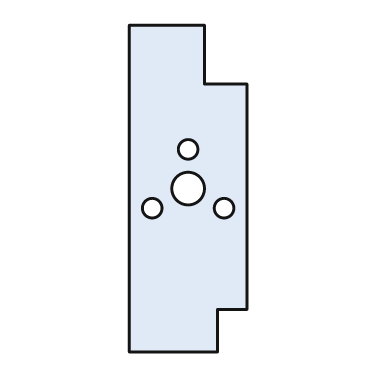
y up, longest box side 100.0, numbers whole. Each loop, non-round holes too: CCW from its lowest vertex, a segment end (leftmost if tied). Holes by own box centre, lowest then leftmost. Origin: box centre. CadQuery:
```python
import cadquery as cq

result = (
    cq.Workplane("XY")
    .moveTo(-18.0, -50.0)
    .lineTo(9.0, -50.0)
    .lineTo(9.0, -37.0)
    .lineTo(18.0, -37.0)
    .lineTo(18.0, 32.0)
    .lineTo(5.0, 32.0)
    .lineTo(5.0, 50.0)
    .lineTo(-18.0, 50.0)
    .close()
    .moveTo(-11.0, -6.0)
    .circle(3.0)
    .moveTo(11.0, -6.0)
    .circle(3.0)
    .moveTo(0.0, 0.0)
    .circle(5.0)
    .moveTo(0.0, 12.0)
    .circle(3.0)
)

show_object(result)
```